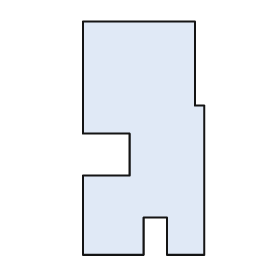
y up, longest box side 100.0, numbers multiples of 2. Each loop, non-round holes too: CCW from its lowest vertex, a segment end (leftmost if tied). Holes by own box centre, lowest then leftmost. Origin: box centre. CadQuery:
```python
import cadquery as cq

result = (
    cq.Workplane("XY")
    .moveTo(-26.0, -50.0)
    .lineTo(0.0, -50.0)
    .lineTo(0.0, -34.0)
    .lineTo(10.0, -34.0)
    .lineTo(10.0, -50.0)
    .lineTo(26.0, -50.0)
    .lineTo(26.0, 14.0)
    .lineTo(22.0, 14.0)
    .lineTo(22.0, 50.0)
    .lineTo(-26.0, 50.0)
    .lineTo(-26.0, 2.0)
    .lineTo(-6.0, 2.0)
    .lineTo(-6.0, -16.0)
    .lineTo(-26.0, -16.0)
    .close()
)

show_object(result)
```